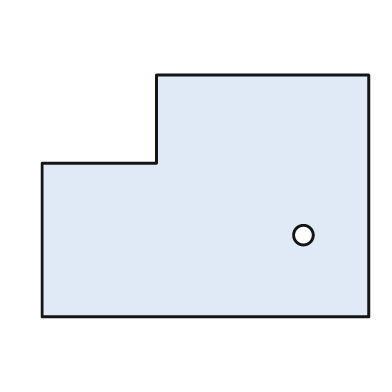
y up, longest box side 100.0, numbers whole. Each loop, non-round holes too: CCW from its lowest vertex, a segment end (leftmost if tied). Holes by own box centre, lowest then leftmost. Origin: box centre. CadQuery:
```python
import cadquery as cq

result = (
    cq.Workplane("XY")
    .moveTo(-50.0, -37.0)
    .lineTo(50.0, -37.0)
    .lineTo(50.0, 37.0)
    .lineTo(-15.0, 37.0)
    .lineTo(-15.0, 10.0)
    .lineTo(-50.0, 10.0)
    .close()
    .moveTo(30.0, -12.0)
    .circle(3.0)
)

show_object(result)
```